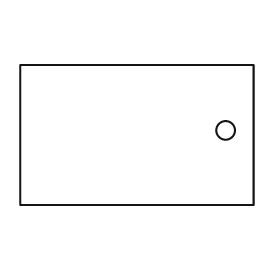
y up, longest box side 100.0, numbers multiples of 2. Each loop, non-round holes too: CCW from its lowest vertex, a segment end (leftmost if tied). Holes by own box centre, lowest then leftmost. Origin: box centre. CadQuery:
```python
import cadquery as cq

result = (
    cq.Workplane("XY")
    .moveTo(-50.0, -30.0)
    .lineTo(50.0, -30.0)
    .lineTo(50.0, 30.0)
    .lineTo(-50.0, 30.0)
    .close()
    .moveTo(38.0, 2.0)
    .circle(4.0)
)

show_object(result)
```